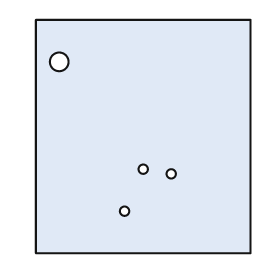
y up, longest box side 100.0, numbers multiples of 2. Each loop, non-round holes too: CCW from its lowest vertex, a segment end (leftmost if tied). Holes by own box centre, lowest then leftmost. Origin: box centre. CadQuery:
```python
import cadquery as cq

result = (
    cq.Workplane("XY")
    .moveTo(-46.0, -50.0)
    .lineTo(46.0, -50.0)
    .lineTo(46.0, 50.0)
    .lineTo(-46.0, 50.0)
    .close()
    .moveTo(-8.0, -32.0)
    .circle(2.0)
    .moveTo(12.0, -16.0)
    .circle(2.0)
    .moveTo(0.0, -14.0)
    .circle(2.0)
    .moveTo(-36.0, 32.0)
    .circle(4.0)
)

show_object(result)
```